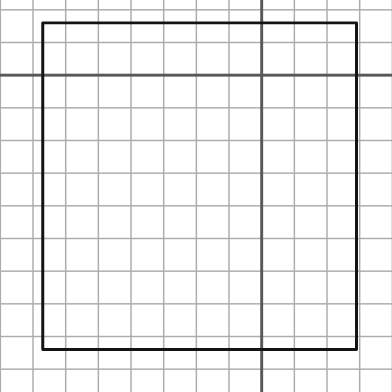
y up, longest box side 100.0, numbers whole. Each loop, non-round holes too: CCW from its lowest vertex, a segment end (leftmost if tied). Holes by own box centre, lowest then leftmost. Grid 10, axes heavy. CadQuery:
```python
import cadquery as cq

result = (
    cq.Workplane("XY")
    .moveTo(-67.0, -84.0)
    .lineTo(29.0, -84.0)
    .lineTo(29.0, 16.0)
    .lineTo(-67.0, 16.0)
    .close()
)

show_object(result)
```